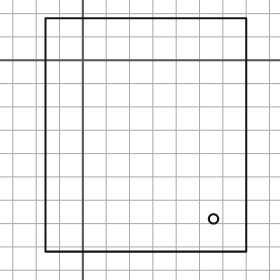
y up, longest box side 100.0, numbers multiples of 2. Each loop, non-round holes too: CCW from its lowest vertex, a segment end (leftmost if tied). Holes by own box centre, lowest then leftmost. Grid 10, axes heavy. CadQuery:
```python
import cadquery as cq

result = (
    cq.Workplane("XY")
    .moveTo(-16.0, -82.0)
    .lineTo(70.0, -82.0)
    .lineTo(70.0, 18.0)
    .lineTo(-16.0, 18.0)
    .close()
    .moveTo(56.0, -68.0)
    .circle(2.0)
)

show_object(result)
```